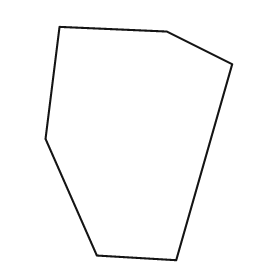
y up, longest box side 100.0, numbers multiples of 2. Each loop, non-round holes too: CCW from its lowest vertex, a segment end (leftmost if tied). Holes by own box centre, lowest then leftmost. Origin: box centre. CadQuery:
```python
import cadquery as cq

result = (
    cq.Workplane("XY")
    .moveTo(16.0, -50.0)
    .lineTo(40.0, 34.0)
    .lineTo(12.0, 48.0)
    .lineTo(-34.0, 50.0)
    .lineTo(-40.0, 2.0)
    .lineTo(-18.0, -48.0)
    .close()
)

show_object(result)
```